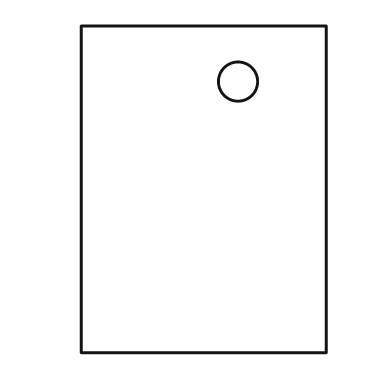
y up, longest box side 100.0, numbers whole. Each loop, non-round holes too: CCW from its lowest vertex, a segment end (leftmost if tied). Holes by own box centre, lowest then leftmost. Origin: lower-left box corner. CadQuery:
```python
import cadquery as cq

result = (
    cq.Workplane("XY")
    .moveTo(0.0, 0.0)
    .lineTo(75.0, 0.0)
    .lineTo(75.0, 100.0)
    .lineTo(0.0, 100.0)
    .close()
    .moveTo(48.0, 83.0)
    .circle(6.0)
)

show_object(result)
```